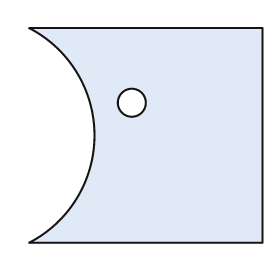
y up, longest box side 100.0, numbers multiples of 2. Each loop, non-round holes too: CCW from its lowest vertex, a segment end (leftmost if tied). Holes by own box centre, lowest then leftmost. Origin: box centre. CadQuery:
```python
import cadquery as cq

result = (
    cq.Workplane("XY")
    .moveTo(-50.0, -46.0)
    .lineTo(50.0, -46.0)
    .lineTo(50.0, 46.0)
    .lineTo(-50.0, 46.0)
    .threePointArc((-22.0, 0.0), (-50.0, -46.0))
    .close()
    .moveTo(-6.0, 14.0)
    .circle(6.0)
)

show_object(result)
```